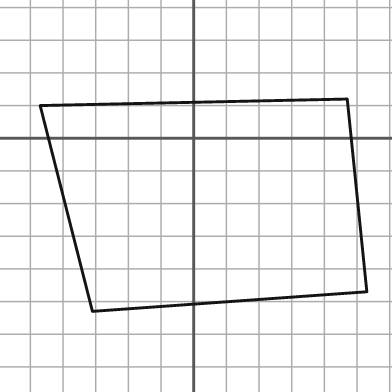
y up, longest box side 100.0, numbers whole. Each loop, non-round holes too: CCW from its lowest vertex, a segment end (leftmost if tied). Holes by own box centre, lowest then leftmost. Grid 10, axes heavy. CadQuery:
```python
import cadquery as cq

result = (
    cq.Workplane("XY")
    .moveTo(-31.0, -53.0)
    .lineTo(53.0, -47.0)
    .lineTo(47.0, 12.0)
    .lineTo(-47.0, 10.0)
    .close()
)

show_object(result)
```